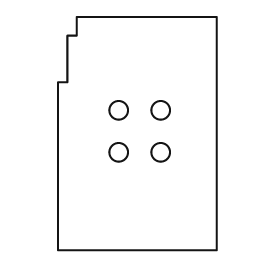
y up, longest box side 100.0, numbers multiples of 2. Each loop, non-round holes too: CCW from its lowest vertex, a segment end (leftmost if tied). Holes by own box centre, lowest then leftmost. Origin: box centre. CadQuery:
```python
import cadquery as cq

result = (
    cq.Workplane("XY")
    .moveTo(-34.0, -50.0)
    .lineTo(34.0, -50.0)
    .lineTo(34.0, 50.0)
    .lineTo(-26.0, 50.0)
    .lineTo(-26.0, 42.0)
    .lineTo(-30.0, 42.0)
    .lineTo(-30.0, 22.0)
    .lineTo(-34.0, 22.0)
    .close()
    .moveTo(-8.0, -8.0)
    .circle(4.0)
    .moveTo(10.0, -8.0)
    .circle(4.0)
    .moveTo(-8.0, 10.0)
    .circle(4.0)
    .moveTo(10.0, 10.0)
    .circle(4.0)
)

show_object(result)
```